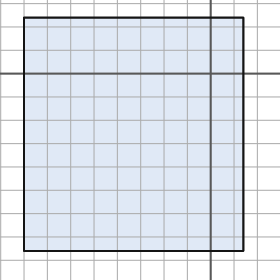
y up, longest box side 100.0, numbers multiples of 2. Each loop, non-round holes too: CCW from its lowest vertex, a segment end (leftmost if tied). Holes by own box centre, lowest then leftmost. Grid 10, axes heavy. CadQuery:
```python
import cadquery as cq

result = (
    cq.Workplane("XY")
    .moveTo(-80.0, -76.0)
    .lineTo(14.0, -76.0)
    .lineTo(14.0, 24.0)
    .lineTo(-80.0, 24.0)
    .close()
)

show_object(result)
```